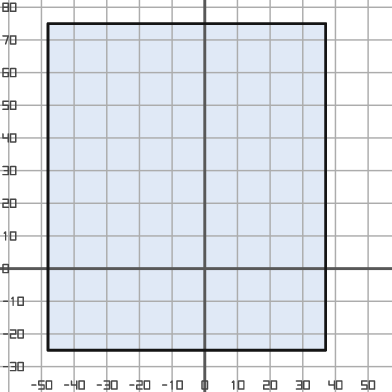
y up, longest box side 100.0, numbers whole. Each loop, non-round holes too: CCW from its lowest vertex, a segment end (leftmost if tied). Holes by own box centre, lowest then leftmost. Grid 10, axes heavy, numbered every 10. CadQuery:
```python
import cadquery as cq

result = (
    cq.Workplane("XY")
    .moveTo(-48.0, -25.0)
    .lineTo(37.0, -25.0)
    .lineTo(37.0, 75.0)
    .lineTo(-48.0, 75.0)
    .close()
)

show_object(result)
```